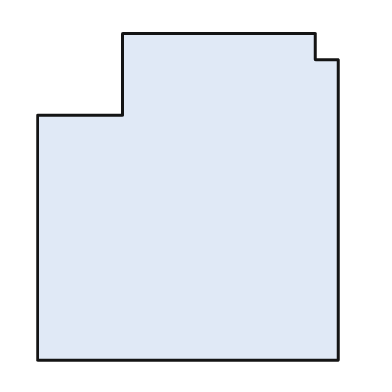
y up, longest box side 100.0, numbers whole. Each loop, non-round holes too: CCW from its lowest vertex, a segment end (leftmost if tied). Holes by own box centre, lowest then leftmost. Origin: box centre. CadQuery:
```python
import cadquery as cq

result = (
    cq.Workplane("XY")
    .moveTo(-46.0, -50.0)
    .lineTo(46.0, -50.0)
    .lineTo(46.0, 42.0)
    .lineTo(39.0, 42.0)
    .lineTo(39.0, 50.0)
    .lineTo(-20.0, 50.0)
    .lineTo(-20.0, 25.0)
    .lineTo(-46.0, 25.0)
    .close()
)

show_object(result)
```